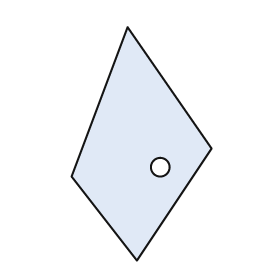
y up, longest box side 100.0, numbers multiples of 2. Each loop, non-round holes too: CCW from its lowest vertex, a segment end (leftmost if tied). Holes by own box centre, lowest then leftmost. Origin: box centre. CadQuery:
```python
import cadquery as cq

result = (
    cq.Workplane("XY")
    .moveTo(-2.0, -50.0)
    .lineTo(30.0, -2.0)
    .lineTo(-6.0, 50.0)
    .lineTo(-30.0, -14.0)
    .close()
    .moveTo(8.0, -10.0)
    .circle(4.0)
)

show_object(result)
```